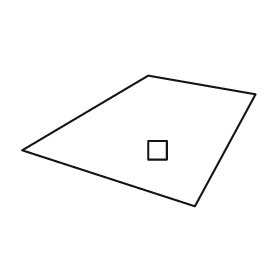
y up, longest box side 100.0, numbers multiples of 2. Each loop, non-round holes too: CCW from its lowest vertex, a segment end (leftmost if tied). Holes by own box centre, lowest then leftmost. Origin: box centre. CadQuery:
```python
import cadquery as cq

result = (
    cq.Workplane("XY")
    .moveTo(24.0, -28.0)
    .lineTo(50.0, 20.0)
    .lineTo(4.0, 28.0)
    .lineTo(-50.0, -4.0)
    .close()
    .moveTo(4.0, -8.0)
    .lineTo(12.0, -8.0)
    .lineTo(12.0, 0.0)
    .lineTo(4.0, 0.0)
    .close()
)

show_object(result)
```